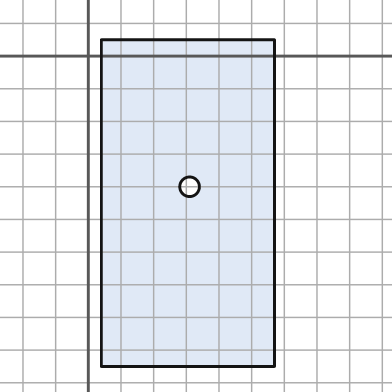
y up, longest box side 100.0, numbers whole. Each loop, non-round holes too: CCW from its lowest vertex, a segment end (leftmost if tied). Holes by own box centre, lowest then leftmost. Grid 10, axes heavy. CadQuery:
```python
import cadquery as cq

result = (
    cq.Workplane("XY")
    .moveTo(4.0, -95.0)
    .lineTo(57.0, -95.0)
    .lineTo(57.0, 5.0)
    .lineTo(4.0, 5.0)
    .close()
    .moveTo(31.0, -40.0)
    .circle(3.0)
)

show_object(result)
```